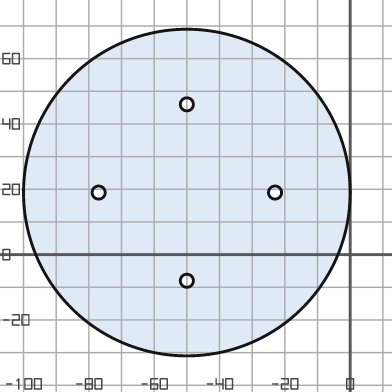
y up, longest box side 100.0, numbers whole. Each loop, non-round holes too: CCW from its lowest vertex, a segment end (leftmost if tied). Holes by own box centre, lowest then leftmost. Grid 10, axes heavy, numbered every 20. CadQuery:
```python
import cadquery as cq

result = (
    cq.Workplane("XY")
    .moveTo(-50.0, 19.0)
    .circle(50.0)
    .moveTo(-50.0, -8.0)
    .circle(2.0)
    .moveTo(-77.0, 19.0)
    .circle(2.0)
    .moveTo(-23.0, 19.0)
    .circle(2.0)
    .moveTo(-50.0, 46.0)
    .circle(2.0)
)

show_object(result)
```